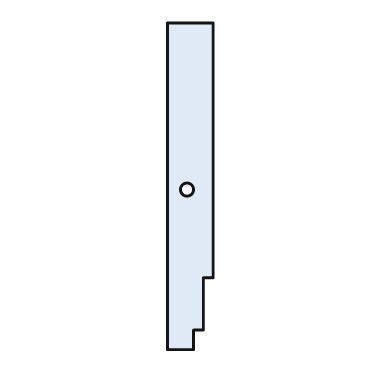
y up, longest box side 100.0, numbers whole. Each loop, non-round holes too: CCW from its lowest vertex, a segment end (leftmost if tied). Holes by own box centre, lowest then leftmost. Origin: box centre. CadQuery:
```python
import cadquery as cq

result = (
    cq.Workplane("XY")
    .moveTo(-7.0, -50.0)
    .lineTo(1.0, -50.0)
    .lineTo(1.0, -44.0)
    .lineTo(4.0, -44.0)
    .lineTo(4.0, -28.0)
    .lineTo(7.0, -28.0)
    .lineTo(7.0, 50.0)
    .lineTo(-7.0, 50.0)
    .close()
    .moveTo(-1.0, -1.0)
    .circle(2.0)
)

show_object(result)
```